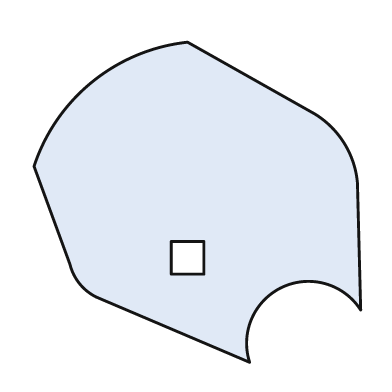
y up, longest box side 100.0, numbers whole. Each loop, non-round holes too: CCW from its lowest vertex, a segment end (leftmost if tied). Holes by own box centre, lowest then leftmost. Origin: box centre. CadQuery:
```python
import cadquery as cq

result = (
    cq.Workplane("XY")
    .moveTo(16.0, -49.0)
    .threePointArc((26.0, -26.0), (50.0, -33.0))
    .lineTo(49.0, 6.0)
    .threePointArc((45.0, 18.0), (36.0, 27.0))
    .lineTo(-3.0, 49.0)
    .threePointArc((-32.0, 37.0), (-50.0, 11.0))
    .lineTo(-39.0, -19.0)
    .threePointArc((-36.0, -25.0), (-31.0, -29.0))
    .close()
    .moveTo(-8.0, -22.0)
    .lineTo(2.0, -22.0)
    .lineTo(2.0, -12.0)
    .lineTo(-8.0, -12.0)
    .close()
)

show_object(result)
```